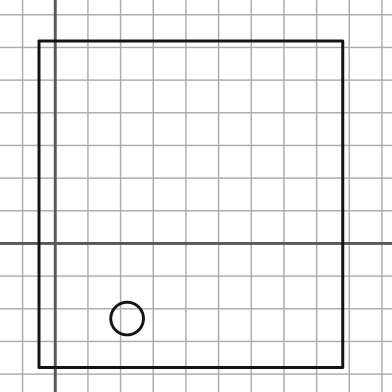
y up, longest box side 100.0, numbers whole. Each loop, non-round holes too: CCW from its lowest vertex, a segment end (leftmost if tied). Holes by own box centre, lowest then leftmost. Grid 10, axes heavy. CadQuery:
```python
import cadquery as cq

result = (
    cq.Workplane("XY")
    .moveTo(-5.0, -38.0)
    .lineTo(88.0, -38.0)
    .lineTo(88.0, 62.0)
    .lineTo(-5.0, 62.0)
    .close()
    .moveTo(22.0, -23.0)
    .circle(5.0)
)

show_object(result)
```